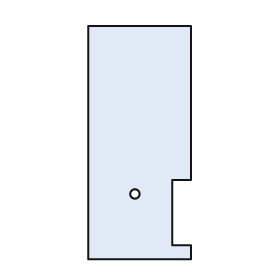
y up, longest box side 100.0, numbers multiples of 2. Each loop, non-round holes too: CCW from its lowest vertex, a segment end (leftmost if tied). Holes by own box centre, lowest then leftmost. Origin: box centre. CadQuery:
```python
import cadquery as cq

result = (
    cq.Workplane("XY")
    .moveTo(-22.0, -50.0)
    .lineTo(22.0, -50.0)
    .lineTo(22.0, -44.0)
    .lineTo(14.0, -44.0)
    .lineTo(14.0, -16.0)
    .lineTo(22.0, -16.0)
    .lineTo(22.0, 50.0)
    .lineTo(-22.0, 50.0)
    .close()
    .moveTo(-2.0, -22.0)
    .circle(2.0)
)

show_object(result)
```